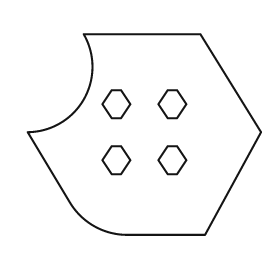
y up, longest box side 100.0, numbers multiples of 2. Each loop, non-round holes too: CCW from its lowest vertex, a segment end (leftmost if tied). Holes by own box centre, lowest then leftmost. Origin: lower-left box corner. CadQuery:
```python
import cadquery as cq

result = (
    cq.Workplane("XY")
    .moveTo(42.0, 0.0)
    .lineTo(76.0, 0.0)
    .lineTo(100.0, 44.0)
    .lineTo(74.0, 86.0)
    .lineTo(24.0, 86.0)
    .threePointArc((24.0, 58.0), (0.0, 44.0))
    .lineTo(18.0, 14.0)
    .threePointArc((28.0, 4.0), (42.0, 0.0))
    .close()
    .moveTo(36.0, 26.0)
    .lineTo(40.0, 26.0)
    .lineTo(44.0, 32.0)
    .lineTo(40.0, 38.0)
    .lineTo(36.0, 38.0)
    .lineTo(32.0, 32.0)
    .close()
    .moveTo(60.0, 26.0)
    .lineTo(64.0, 26.0)
    .lineTo(68.0, 32.0)
    .lineTo(64.0, 38.0)
    .lineTo(60.0, 38.0)
    .lineTo(56.0, 32.0)
    .close()
    .moveTo(36.0, 50.0)
    .lineTo(40.0, 50.0)
    .lineTo(44.0, 56.0)
    .lineTo(40.0, 62.0)
    .lineTo(36.0, 62.0)
    .lineTo(32.0, 56.0)
    .close()
    .moveTo(60.0, 50.0)
    .lineTo(64.0, 50.0)
    .lineTo(68.0, 56.0)
    .lineTo(64.0, 62.0)
    .lineTo(60.0, 62.0)
    .lineTo(56.0, 56.0)
    .close()
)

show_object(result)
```